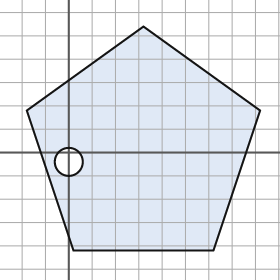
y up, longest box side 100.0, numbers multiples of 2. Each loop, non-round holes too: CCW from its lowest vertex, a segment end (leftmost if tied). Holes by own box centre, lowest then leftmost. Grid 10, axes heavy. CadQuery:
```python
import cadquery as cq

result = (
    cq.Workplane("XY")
    .moveTo(2.0, -42.0)
    .lineTo(62.0, -42.0)
    .lineTo(82.0, 18.0)
    .lineTo(32.0, 54.0)
    .lineTo(-18.0, 18.0)
    .close()
    .moveTo(0.0, -4.0)
    .circle(6.0)
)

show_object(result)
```